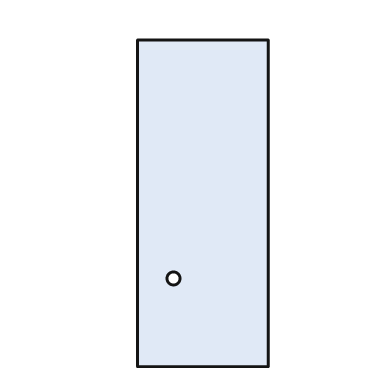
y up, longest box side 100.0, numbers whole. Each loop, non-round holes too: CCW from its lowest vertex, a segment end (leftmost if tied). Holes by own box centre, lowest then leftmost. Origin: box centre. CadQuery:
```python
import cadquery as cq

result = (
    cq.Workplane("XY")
    .moveTo(-20.0, -50.0)
    .lineTo(20.0, -50.0)
    .lineTo(20.0, 50.0)
    .lineTo(-20.0, 50.0)
    .close()
    .moveTo(-9.0, -23.0)
    .circle(2.0)
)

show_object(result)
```